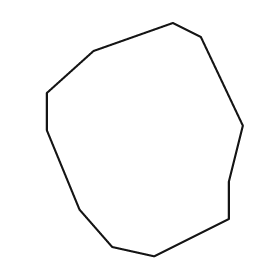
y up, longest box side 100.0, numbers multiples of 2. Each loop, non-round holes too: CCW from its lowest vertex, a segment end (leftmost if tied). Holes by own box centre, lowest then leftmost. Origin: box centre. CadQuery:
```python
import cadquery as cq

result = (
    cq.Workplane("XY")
    .moveTo(4.0, -50.0)
    .lineTo(36.0, -34.0)
    .lineTo(36.0, -18.0)
    .lineTo(42.0, 6.0)
    .lineTo(24.0, 44.0)
    .lineTo(12.0, 50.0)
    .lineTo(-22.0, 38.0)
    .lineTo(-42.0, 20.0)
    .lineTo(-42.0, 4.0)
    .lineTo(-28.0, -30.0)
    .lineTo(-14.0, -46.0)
    .close()
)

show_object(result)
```